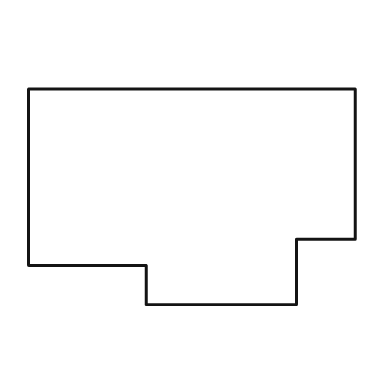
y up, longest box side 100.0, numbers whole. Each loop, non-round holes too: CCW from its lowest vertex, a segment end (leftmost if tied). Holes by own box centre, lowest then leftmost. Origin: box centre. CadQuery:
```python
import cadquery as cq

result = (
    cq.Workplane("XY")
    .moveTo(-14.0, -33.0)
    .lineTo(32.0, -33.0)
    .lineTo(32.0, -13.0)
    .lineTo(50.0, -13.0)
    .lineTo(50.0, 33.0)
    .lineTo(-50.0, 33.0)
    .lineTo(-50.0, -21.0)
    .lineTo(-14.0, -21.0)
    .close()
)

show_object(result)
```